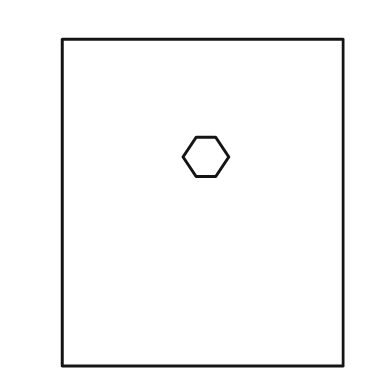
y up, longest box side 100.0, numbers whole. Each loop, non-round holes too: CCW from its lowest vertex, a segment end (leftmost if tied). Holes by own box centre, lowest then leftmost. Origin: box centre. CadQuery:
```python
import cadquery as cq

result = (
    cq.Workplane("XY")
    .moveTo(-43.0, -50.0)
    .lineTo(43.0, -50.0)
    .lineTo(43.0, 50.0)
    .lineTo(-43.0, 50.0)
    .close()
    .moveTo(-2.0, 8.0)
    .lineTo(4.0, 8.0)
    .lineTo(8.0, 14.0)
    .lineTo(4.0, 20.0)
    .lineTo(-2.0, 20.0)
    .lineTo(-6.0, 14.0)
    .close()
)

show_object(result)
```